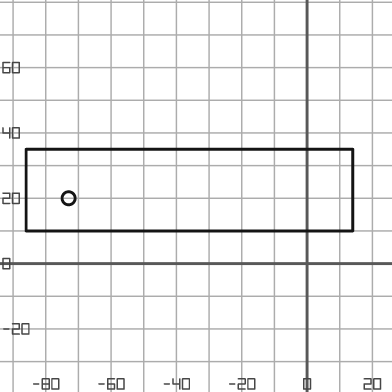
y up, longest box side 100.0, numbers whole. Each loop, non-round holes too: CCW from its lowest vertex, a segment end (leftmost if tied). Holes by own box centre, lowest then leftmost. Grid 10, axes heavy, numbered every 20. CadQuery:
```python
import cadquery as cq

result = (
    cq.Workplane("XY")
    .moveTo(-86.0, 10.0)
    .lineTo(14.0, 10.0)
    .lineTo(14.0, 35.0)
    .lineTo(-86.0, 35.0)
    .close()
    .moveTo(-73.0, 20.0)
    .circle(2.0)
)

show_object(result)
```